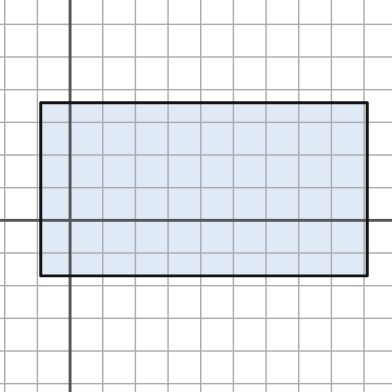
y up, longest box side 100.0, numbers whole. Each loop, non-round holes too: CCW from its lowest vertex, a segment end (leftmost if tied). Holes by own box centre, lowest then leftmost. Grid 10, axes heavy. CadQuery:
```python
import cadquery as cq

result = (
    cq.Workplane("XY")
    .moveTo(-9.0, -17.0)
    .lineTo(91.0, -17.0)
    .lineTo(91.0, 36.0)
    .lineTo(-9.0, 36.0)
    .close()
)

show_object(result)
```